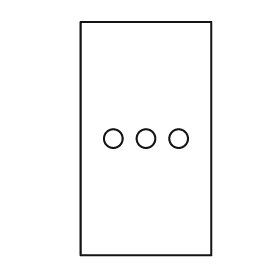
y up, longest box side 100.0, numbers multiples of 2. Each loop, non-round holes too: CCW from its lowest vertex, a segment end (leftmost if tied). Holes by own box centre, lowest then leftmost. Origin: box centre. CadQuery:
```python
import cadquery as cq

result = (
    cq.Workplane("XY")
    .moveTo(-28.0, -50.0)
    .lineTo(28.0, -50.0)
    .lineTo(28.0, 50.0)
    .lineTo(-28.0, 50.0)
    .close()
    .moveTo(-14.0, 0.0)
    .circle(4.0)
    .moveTo(0.0, 0.0)
    .circle(4.0)
    .moveTo(14.0, 0.0)
    .circle(4.0)
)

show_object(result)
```